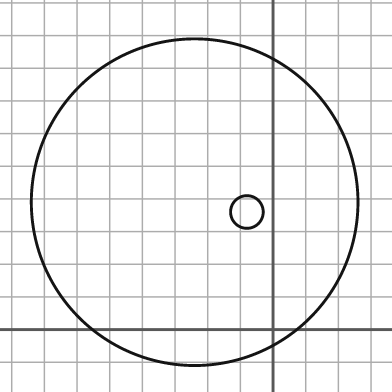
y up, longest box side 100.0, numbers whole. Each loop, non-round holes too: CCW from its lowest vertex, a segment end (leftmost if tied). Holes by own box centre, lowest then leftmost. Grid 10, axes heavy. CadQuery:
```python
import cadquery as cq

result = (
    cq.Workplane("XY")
    .moveTo(-24.0, 39.0)
    .circle(50.0)
    .moveTo(-8.0, 36.0)
    .circle(5.0)
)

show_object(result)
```